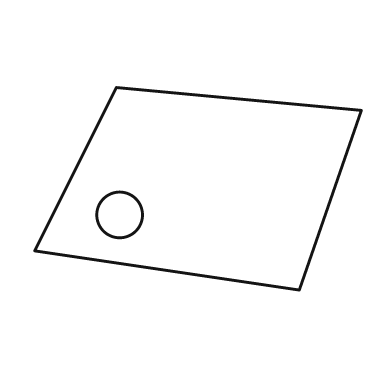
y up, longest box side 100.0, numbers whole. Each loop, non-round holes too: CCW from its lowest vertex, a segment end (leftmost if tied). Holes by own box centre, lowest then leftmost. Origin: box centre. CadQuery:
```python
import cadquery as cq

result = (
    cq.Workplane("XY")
    .moveTo(31.0, -31.0)
    .lineTo(50.0, 24.0)
    .lineTo(-25.0, 31.0)
    .lineTo(-50.0, -19.0)
    .close()
    .moveTo(-24.0, -8.0)
    .circle(7.0)
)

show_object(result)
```